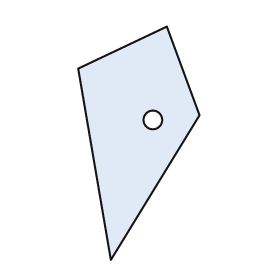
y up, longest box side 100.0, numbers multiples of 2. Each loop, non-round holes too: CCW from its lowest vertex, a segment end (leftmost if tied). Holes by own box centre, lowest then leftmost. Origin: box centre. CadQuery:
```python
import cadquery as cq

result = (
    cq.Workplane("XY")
    .moveTo(-12.0, -50.0)
    .lineTo(26.0, 12.0)
    .lineTo(12.0, 50.0)
    .lineTo(-26.0, 32.0)
    .close()
    .moveTo(6.0, 10.0)
    .circle(4.0)
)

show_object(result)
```